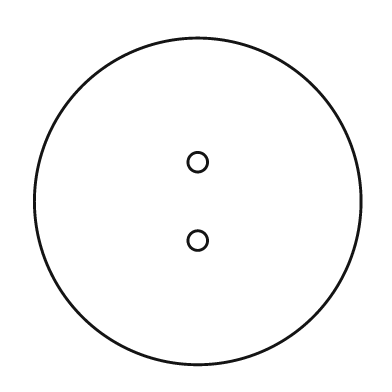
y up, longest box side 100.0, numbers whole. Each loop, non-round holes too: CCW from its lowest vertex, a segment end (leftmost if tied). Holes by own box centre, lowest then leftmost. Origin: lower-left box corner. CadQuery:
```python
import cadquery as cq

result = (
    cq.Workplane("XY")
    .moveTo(50.0, 50.0)
    .circle(50.0)
    .moveTo(50.0, 38.0)
    .circle(3.0)
    .moveTo(50.0, 62.0)
    .circle(3.0)
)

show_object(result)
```